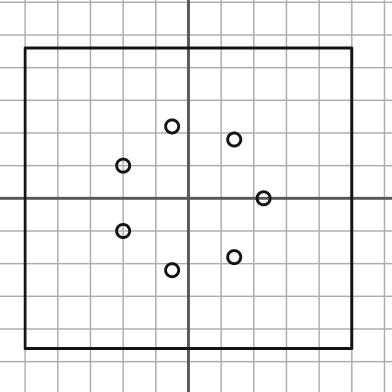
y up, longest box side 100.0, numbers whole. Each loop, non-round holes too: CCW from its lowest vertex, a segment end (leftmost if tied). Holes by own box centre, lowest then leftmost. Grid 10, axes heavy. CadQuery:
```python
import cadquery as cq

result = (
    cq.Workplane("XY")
    .moveTo(-50.0, -46.0)
    .lineTo(50.0, -46.0)
    .lineTo(50.0, 46.0)
    .lineTo(-50.0, 46.0)
    .close()
    .moveTo(-5.0, -22.0)
    .circle(2.0)
    .moveTo(14.0, -18.0)
    .circle(2.0)
    .moveTo(-20.0, -10.0)
    .circle(2.0)
    .moveTo(23.0, 0.0)
    .circle(2.0)
    .moveTo(-20.0, 10.0)
    .circle(2.0)
    .moveTo(14.0, 18.0)
    .circle(2.0)
    .moveTo(-5.0, 22.0)
    .circle(2.0)
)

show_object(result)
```